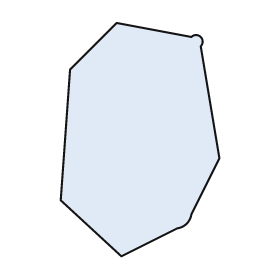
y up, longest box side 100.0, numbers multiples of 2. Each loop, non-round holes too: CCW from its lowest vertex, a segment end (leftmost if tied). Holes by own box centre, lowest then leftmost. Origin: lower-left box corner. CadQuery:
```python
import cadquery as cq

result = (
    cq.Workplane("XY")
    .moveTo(26.0, 0.0)
    .lineTo(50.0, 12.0)
    .threePointArc((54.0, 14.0), (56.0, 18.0))
    .lineTo(68.0, 42.0)
    .lineTo(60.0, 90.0)
    .threePointArc((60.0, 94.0), (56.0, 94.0))
    .lineTo(24.0, 100.0)
    .lineTo(4.0, 80.0)
    .lineTo(0.0, 24.0)
    .close()
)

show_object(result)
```